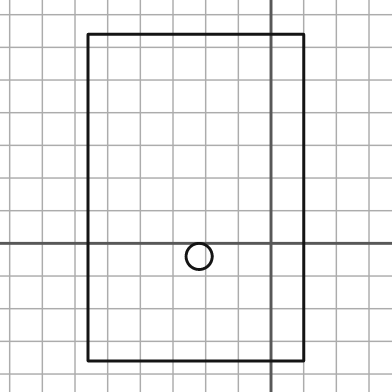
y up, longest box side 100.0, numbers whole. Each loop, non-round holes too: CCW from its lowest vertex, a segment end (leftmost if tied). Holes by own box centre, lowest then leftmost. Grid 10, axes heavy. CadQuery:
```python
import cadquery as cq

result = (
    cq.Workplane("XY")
    .moveTo(-56.0, -36.0)
    .lineTo(10.0, -36.0)
    .lineTo(10.0, 64.0)
    .lineTo(-56.0, 64.0)
    .close()
    .moveTo(-22.0, -4.0)
    .circle(4.0)
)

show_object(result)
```